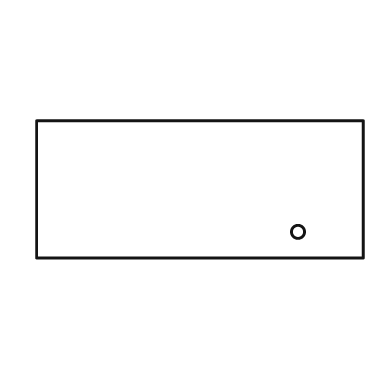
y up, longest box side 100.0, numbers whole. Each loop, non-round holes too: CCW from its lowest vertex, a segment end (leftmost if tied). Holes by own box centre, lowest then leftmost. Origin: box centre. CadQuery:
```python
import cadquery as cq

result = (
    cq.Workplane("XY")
    .moveTo(-50.0, -21.0)
    .lineTo(50.0, -21.0)
    .lineTo(50.0, 21.0)
    .lineTo(-50.0, 21.0)
    .close()
    .moveTo(30.0, -13.0)
    .circle(2.0)
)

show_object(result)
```